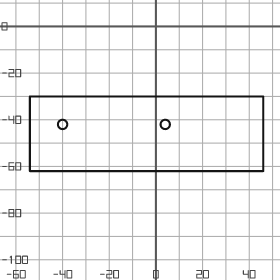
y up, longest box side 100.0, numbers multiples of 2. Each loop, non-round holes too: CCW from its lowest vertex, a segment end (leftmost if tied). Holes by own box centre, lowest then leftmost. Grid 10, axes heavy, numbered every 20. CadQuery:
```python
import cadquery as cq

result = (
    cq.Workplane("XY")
    .moveTo(-54.0, -62.0)
    .lineTo(46.0, -62.0)
    .lineTo(46.0, -30.0)
    .lineTo(-54.0, -30.0)
    .close()
    .moveTo(-40.0, -42.0)
    .circle(2.0)
    .moveTo(4.0, -42.0)
    .circle(2.0)
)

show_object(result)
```